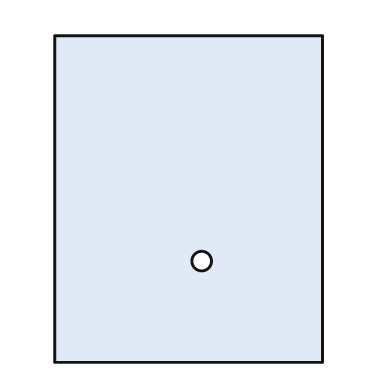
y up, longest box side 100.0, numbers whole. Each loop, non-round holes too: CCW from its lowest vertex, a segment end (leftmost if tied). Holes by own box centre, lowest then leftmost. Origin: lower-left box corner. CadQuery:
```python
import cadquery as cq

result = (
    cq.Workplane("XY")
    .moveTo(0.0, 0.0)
    .lineTo(82.0, 0.0)
    .lineTo(82.0, 100.0)
    .lineTo(0.0, 100.0)
    .close()
    .moveTo(45.0, 31.0)
    .circle(3.0)
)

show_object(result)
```